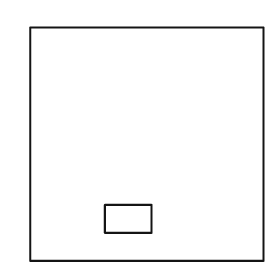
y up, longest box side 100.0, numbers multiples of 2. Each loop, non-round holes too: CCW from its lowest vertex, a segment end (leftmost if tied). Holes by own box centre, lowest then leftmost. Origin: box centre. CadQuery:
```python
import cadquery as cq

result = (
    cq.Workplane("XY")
    .moveTo(-50.0, -50.0)
    .lineTo(50.0, -50.0)
    .lineTo(50.0, 50.0)
    .lineTo(-50.0, 50.0)
    .close()
    .moveTo(-18.0, -38.0)
    .lineTo(2.0, -38.0)
    .lineTo(2.0, -26.0)
    .lineTo(-18.0, -26.0)
    .close()
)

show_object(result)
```